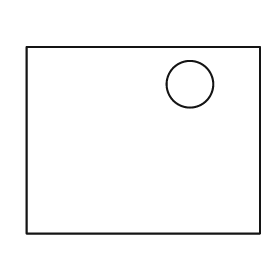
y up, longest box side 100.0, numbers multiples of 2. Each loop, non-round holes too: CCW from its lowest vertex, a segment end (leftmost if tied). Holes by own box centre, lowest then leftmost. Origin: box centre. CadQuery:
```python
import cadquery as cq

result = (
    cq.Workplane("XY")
    .moveTo(-50.0, -40.0)
    .lineTo(50.0, -40.0)
    .lineTo(50.0, 40.0)
    .lineTo(-50.0, 40.0)
    .close()
    .moveTo(20.0, 24.0)
    .circle(10.0)
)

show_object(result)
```